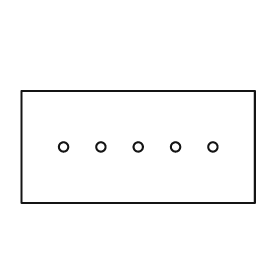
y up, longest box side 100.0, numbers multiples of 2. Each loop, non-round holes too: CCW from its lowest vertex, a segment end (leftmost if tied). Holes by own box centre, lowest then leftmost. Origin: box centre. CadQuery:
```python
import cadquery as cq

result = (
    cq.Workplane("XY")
    .moveTo(-50.0, -24.0)
    .lineTo(50.0, -24.0)
    .lineTo(50.0, 24.0)
    .lineTo(-50.0, 24.0)
    .close()
    .moveTo(-32.0, 0.0)
    .circle(2.0)
    .moveTo(-16.0, 0.0)
    .circle(2.0)
    .moveTo(0.0, 0.0)
    .circle(2.0)
    .moveTo(16.0, 0.0)
    .circle(2.0)
    .moveTo(32.0, 0.0)
    .circle(2.0)
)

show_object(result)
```